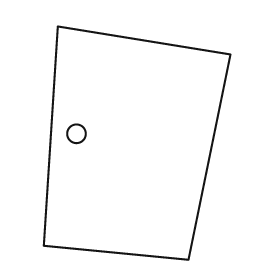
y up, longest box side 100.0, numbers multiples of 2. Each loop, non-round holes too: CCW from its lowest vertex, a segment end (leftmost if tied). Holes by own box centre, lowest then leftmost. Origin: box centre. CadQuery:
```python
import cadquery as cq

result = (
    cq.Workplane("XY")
    .moveTo(22.0, -50.0)
    .lineTo(40.0, 38.0)
    .lineTo(-34.0, 50.0)
    .lineTo(-40.0, -44.0)
    .close()
    .moveTo(-26.0, 4.0)
    .circle(4.0)
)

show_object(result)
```